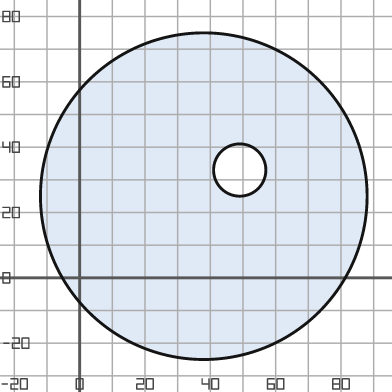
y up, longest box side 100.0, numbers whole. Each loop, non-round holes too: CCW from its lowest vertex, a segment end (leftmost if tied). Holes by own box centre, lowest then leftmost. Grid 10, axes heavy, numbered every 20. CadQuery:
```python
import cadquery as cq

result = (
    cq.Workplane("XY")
    .moveTo(38.0, 25.0)
    .circle(50.0)
    .moveTo(49.0, 33.0)
    .circle(8.0)
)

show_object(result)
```